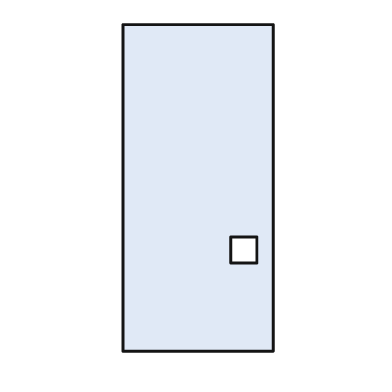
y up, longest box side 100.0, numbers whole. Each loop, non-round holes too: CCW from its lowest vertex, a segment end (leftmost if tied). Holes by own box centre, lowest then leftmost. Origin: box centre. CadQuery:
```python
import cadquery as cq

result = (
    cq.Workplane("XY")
    .moveTo(-23.0, -50.0)
    .lineTo(23.0, -50.0)
    .lineTo(23.0, 50.0)
    .lineTo(-23.0, 50.0)
    .close()
    .moveTo(10.0, -23.0)
    .lineTo(18.0, -23.0)
    .lineTo(18.0, -15.0)
    .lineTo(10.0, -15.0)
    .close()
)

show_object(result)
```